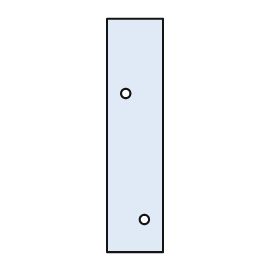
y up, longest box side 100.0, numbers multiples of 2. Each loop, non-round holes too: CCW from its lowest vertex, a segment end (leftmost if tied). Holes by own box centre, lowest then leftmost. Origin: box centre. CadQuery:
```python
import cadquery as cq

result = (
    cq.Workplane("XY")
    .moveTo(-12.0, -50.0)
    .lineTo(12.0, -50.0)
    .lineTo(12.0, 50.0)
    .lineTo(-12.0, 50.0)
    .close()
    .moveTo(4.0, -36.0)
    .circle(2.0)
    .moveTo(-4.0, 18.0)
    .circle(2.0)
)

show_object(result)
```